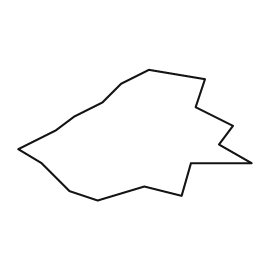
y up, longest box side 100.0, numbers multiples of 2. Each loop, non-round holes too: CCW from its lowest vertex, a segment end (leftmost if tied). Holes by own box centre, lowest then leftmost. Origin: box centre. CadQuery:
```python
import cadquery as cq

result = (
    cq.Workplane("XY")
    .moveTo(-16.0, -28.0)
    .lineTo(4.0, -22.0)
    .lineTo(20.0, -26.0)
    .lineTo(24.0, -12.0)
    .lineTo(50.0, -12.0)
    .lineTo(36.0, -4.0)
    .lineTo(42.0, 4.0)
    .lineTo(26.0, 12.0)
    .lineTo(30.0, 24.0)
    .lineTo(6.0, 28.0)
    .lineTo(-6.0, 22.0)
    .lineTo(-14.0, 14.0)
    .lineTo(-26.0, 8.0)
    .lineTo(-34.0, 2.0)
    .lineTo(-50.0, -6.0)
    .lineTo(-40.0, -12.0)
    .lineTo(-28.0, -24.0)
    .close()
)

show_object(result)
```